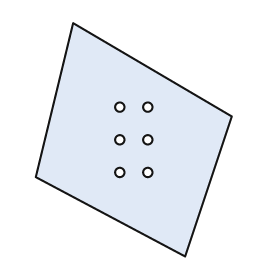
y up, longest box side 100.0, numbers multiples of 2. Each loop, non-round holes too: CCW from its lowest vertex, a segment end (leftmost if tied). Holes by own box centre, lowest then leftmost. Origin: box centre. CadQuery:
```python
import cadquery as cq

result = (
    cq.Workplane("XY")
    .moveTo(22.0, -50.0)
    .lineTo(42.0, 10.0)
    .lineTo(-26.0, 50.0)
    .lineTo(-42.0, -16.0)
    .close()
    .moveTo(-6.0, -14.0)
    .circle(2.0)
    .moveTo(6.0, -14.0)
    .circle(2.0)
    .moveTo(-6.0, 0.0)
    .circle(2.0)
    .moveTo(6.0, 0.0)
    .circle(2.0)
    .moveTo(-6.0, 14.0)
    .circle(2.0)
    .moveTo(6.0, 14.0)
    .circle(2.0)
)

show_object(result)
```